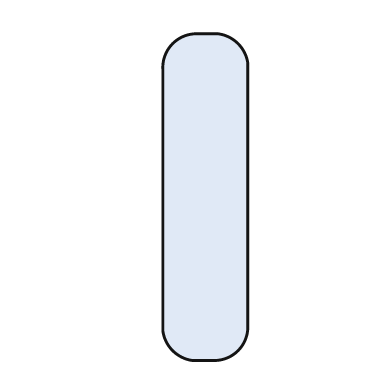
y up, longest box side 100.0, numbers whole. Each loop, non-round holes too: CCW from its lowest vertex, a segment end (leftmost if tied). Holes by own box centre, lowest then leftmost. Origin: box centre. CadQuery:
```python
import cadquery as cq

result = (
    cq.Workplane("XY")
    .moveTo(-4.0, -50.0)
    .lineTo(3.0, -50.0)
    .threePointArc((10.0, -47.0), (13.0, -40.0))
    .lineTo(13.0, 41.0)
    .threePointArc((10.0, 47.0), (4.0, 50.0))
    .lineTo(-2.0, 50.0)
    .threePointArc((-10.0, 47.0), (-13.0, 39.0))
    .lineTo(-13.0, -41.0)
    .threePointArc((-10.0, -47.0), (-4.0, -50.0))
    .close()
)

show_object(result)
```